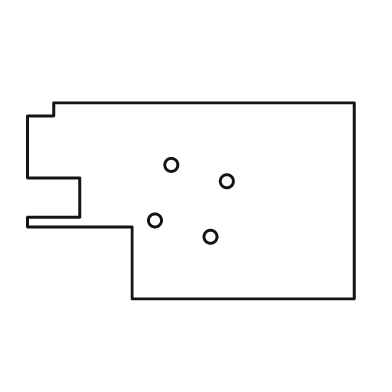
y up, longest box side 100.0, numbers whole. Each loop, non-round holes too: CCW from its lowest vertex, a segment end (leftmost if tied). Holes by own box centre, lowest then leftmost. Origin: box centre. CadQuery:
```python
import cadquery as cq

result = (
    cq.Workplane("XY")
    .moveTo(-18.0, -30.0)
    .lineTo(50.0, -30.0)
    .lineTo(50.0, 30.0)
    .lineTo(-42.0, 30.0)
    .lineTo(-42.0, 26.0)
    .lineTo(-50.0, 26.0)
    .lineTo(-50.0, 7.0)
    .lineTo(-34.0, 7.0)
    .lineTo(-34.0, -5.0)
    .lineTo(-50.0, -5.0)
    .lineTo(-50.0, -8.0)
    .lineTo(-18.0, -8.0)
    .close()
    .moveTo(6.0, -11.0)
    .circle(2.0)
    .moveTo(-11.0, -6.0)
    .circle(2.0)
    .moveTo(11.0, 6.0)
    .circle(2.0)
    .moveTo(-6.0, 11.0)
    .circle(2.0)
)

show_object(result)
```